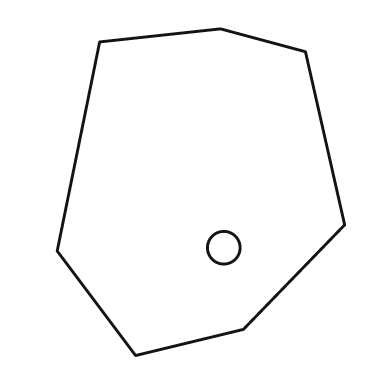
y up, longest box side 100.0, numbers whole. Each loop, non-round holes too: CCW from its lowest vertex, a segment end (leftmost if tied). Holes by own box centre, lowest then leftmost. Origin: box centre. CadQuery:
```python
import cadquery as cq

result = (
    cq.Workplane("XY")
    .moveTo(-20.0, -50.0)
    .lineTo(13.0, -42.0)
    .lineTo(44.0, -10.0)
    .lineTo(32.0, 43.0)
    .lineTo(6.0, 50.0)
    .lineTo(-31.0, 46.0)
    .lineTo(-44.0, -18.0)
    .close()
    .moveTo(7.0, -17.0)
    .circle(5.0)
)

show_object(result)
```